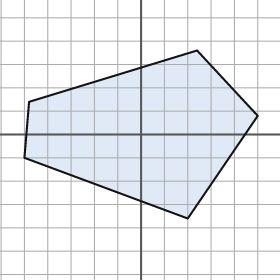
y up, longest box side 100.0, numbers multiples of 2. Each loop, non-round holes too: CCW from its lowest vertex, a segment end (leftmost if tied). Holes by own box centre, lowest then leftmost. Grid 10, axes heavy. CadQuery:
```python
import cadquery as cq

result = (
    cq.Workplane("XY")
    .moveTo(20.0, -36.0)
    .lineTo(50.0, 8.0)
    .lineTo(24.0, 36.0)
    .lineTo(-48.0, 14.0)
    .lineTo(-50.0, -10.0)
    .close()
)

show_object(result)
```